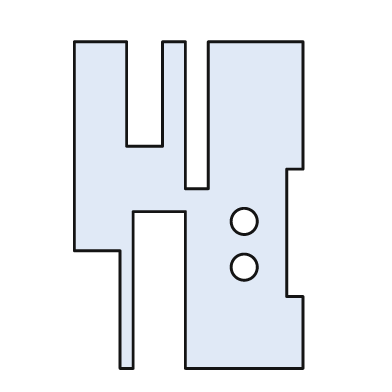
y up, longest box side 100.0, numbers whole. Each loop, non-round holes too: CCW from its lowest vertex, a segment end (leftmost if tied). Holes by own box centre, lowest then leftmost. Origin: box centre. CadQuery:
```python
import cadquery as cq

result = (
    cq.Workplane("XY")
    .moveTo(-21.0, -50.0)
    .lineTo(-17.0, -50.0)
    .lineTo(-17.0, -2.0)
    .lineTo(-1.0, -2.0)
    .lineTo(-1.0, -50.0)
    .lineTo(35.0, -50.0)
    .lineTo(35.0, -28.0)
    .lineTo(30.0, -28.0)
    .lineTo(30.0, 11.0)
    .lineTo(35.0, 11.0)
    .lineTo(35.0, 50.0)
    .lineTo(6.0, 50.0)
    .lineTo(6.0, 5.0)
    .lineTo(-1.0, 5.0)
    .lineTo(-1.0, 50.0)
    .lineTo(-8.0, 50.0)
    .lineTo(-8.0, 18.0)
    .lineTo(-19.0, 18.0)
    .lineTo(-19.0, 50.0)
    .lineTo(-35.0, 50.0)
    .lineTo(-35.0, -14.0)
    .lineTo(-21.0, -14.0)
    .close()
    .moveTo(17.0, -19.0)
    .circle(4.0)
    .moveTo(17.0, -5.0)
    .circle(4.0)
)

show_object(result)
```